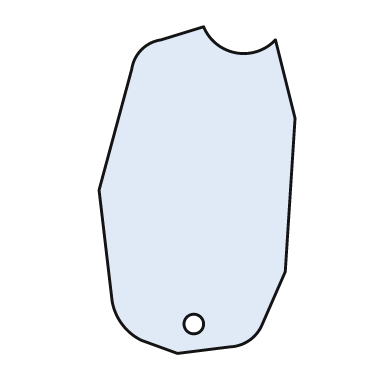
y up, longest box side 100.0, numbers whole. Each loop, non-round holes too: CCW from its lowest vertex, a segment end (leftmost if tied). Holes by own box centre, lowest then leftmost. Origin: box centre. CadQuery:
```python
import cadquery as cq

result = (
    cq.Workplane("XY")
    .moveTo(-6.0, -50.0)
    .lineTo(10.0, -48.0)
    .threePointArc((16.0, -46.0), (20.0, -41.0))
    .lineTo(27.0, -25.0)
    .lineTo(30.0, 22.0)
    .lineTo(24.0, 46.0)
    .threePointArc((12.0, 42.0), (2.0, 50.0))
    .lineTo(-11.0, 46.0)
    .threePointArc((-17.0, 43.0), (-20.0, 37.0))
    .lineTo(-30.0, 0.0)
    .lineTo(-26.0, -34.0)
    .threePointArc((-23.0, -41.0), (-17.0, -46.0))
    .close()
    .moveTo(-1.0, -41.0)
    .circle(3.0)
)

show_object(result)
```